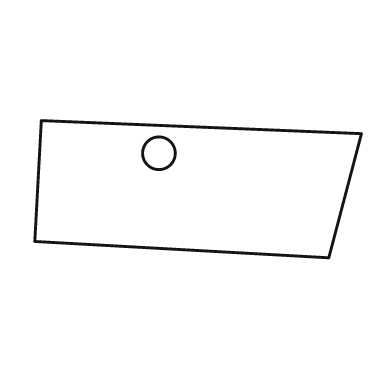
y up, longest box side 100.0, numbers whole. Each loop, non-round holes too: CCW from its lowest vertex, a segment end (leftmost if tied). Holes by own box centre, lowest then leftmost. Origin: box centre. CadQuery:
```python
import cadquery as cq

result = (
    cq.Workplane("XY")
    .moveTo(40.0, -21.0)
    .lineTo(50.0, 17.0)
    .lineTo(-48.0, 21.0)
    .lineTo(-50.0, -16.0)
    .close()
    .moveTo(-12.0, 11.0)
    .circle(5.0)
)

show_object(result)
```